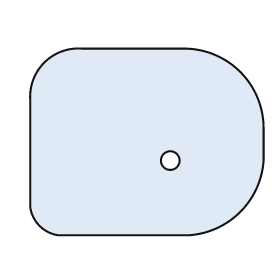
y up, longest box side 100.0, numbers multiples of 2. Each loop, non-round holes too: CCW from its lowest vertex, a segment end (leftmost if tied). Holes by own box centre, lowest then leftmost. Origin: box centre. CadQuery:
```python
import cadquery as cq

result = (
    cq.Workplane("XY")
    .moveTo(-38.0, -40.0)
    .lineTo(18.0, -40.0)
    .threePointArc((40.0, -30.0), (50.0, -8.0))
    .lineTo(50.0, 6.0)
    .threePointArc((40.0, 30.0), (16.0, 40.0))
    .lineTo(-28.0, 40.0)
    .threePointArc((-44.0, 34.0), (-50.0, 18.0))
    .lineTo(-50.0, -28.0)
    .threePointArc((-46.0, -36.0), (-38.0, -40.0))
    .close()
    .moveTo(10.0, -8.0)
    .circle(4.0)
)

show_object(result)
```